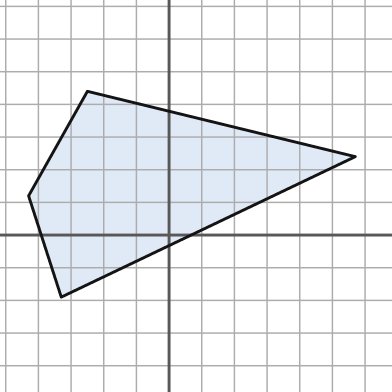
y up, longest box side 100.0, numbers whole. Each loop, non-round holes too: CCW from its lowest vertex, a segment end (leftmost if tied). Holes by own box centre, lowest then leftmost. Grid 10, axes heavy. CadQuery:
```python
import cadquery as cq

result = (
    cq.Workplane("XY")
    .moveTo(-33.0, -19.0)
    .lineTo(57.0, 24.0)
    .lineTo(-25.0, 44.0)
    .lineTo(-43.0, 12.0)
    .close()
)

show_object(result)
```